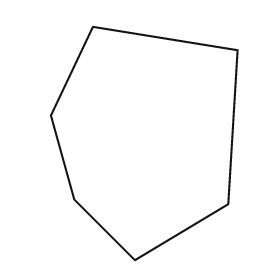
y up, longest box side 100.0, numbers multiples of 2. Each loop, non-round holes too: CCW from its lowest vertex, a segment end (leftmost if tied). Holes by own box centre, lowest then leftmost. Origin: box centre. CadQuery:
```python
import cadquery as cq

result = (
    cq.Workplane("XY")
    .moveTo(-4.0, -50.0)
    .lineTo(36.0, -26.0)
    .lineTo(40.0, 40.0)
    .lineTo(-22.0, 50.0)
    .lineTo(-40.0, 12.0)
    .lineTo(-30.0, -24.0)
    .close()
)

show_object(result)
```